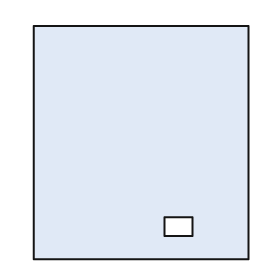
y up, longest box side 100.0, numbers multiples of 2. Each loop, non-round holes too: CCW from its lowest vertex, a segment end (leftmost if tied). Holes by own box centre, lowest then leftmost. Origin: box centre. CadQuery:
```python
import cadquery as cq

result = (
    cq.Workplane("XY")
    .moveTo(-46.0, -50.0)
    .lineTo(46.0, -50.0)
    .lineTo(46.0, 50.0)
    .lineTo(-46.0, 50.0)
    .close()
    .moveTo(10.0, -40.0)
    .lineTo(22.0, -40.0)
    .lineTo(22.0, -32.0)
    .lineTo(10.0, -32.0)
    .close()
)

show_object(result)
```